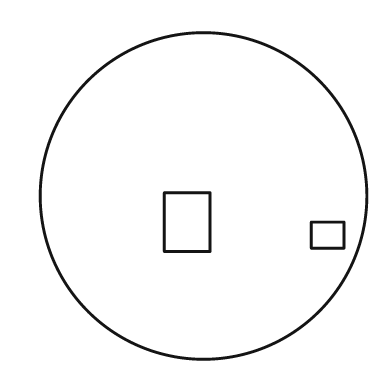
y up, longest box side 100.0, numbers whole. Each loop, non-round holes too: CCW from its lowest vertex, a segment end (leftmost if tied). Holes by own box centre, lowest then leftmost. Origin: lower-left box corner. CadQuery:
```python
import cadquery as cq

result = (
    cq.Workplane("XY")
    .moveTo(50.0, 50.0)
    .circle(50.0)
    .moveTo(83.0, 34.0)
    .lineTo(93.0, 34.0)
    .lineTo(93.0, 42.0)
    .lineTo(83.0, 42.0)
    .close()
    .moveTo(38.0, 33.0)
    .lineTo(52.0, 33.0)
    .lineTo(52.0, 51.0)
    .lineTo(38.0, 51.0)
    .close()
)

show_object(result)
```